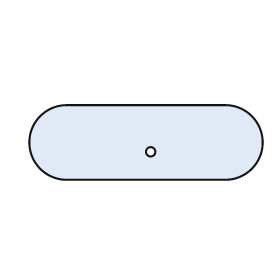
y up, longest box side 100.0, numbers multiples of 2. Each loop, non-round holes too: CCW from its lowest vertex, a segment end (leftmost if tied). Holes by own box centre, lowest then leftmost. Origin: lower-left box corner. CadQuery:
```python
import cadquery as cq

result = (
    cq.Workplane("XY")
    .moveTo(16.0, 0.0)
    .lineTo(84.0, 0.0)
    .threePointArc((100.0, 16.0), (84.0, 32.0))
    .lineTo(16.0, 32.0)
    .threePointArc((0.0, 16.0), (16.0, 0.0))
    .close()
    .moveTo(52.0, 12.0)
    .circle(2.0)
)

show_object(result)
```